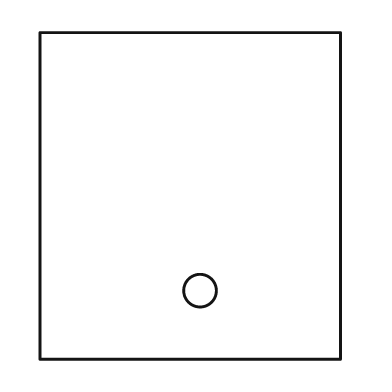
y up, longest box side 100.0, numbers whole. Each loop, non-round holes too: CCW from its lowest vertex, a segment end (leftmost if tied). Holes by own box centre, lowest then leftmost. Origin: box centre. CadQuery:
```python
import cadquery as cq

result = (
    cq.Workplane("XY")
    .moveTo(-46.0, -50.0)
    .lineTo(46.0, -50.0)
    .lineTo(46.0, 50.0)
    .lineTo(-46.0, 50.0)
    .close()
    .moveTo(3.0, -29.0)
    .circle(5.0)
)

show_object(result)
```